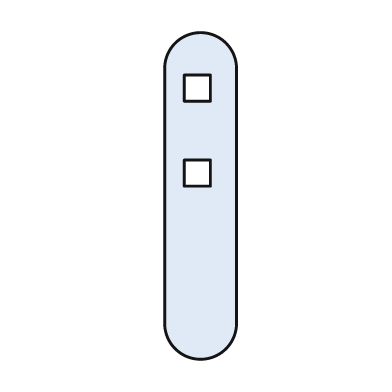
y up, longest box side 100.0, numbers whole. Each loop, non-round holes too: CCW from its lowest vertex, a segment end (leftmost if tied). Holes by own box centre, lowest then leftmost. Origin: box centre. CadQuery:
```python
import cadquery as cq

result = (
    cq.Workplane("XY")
    .moveTo(-11.0, -39.0)
    .threePointArc((0.0, -50.0), (11.0, -39.0))
    .lineTo(11.0, 39.0)
    .threePointArc((0.0, 50.0), (-11.0, 39.0))
    .close()
    .moveTo(-5.0, 3.0)
    .lineTo(3.0, 3.0)
    .lineTo(3.0, 11.0)
    .lineTo(-5.0, 11.0)
    .close()
    .moveTo(-5.0, 29.0)
    .lineTo(3.0, 29.0)
    .lineTo(3.0, 37.0)
    .lineTo(-5.0, 37.0)
    .close()
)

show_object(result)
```